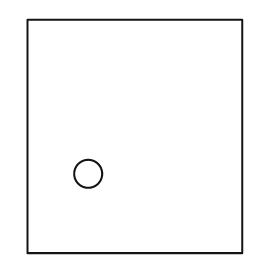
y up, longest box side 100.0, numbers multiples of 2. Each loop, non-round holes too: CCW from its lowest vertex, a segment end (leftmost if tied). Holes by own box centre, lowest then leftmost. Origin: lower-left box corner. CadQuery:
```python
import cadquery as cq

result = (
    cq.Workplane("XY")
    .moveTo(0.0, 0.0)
    .lineTo(92.0, 0.0)
    .lineTo(92.0, 100.0)
    .lineTo(0.0, 100.0)
    .close()
    .moveTo(26.0, 34.0)
    .circle(6.0)
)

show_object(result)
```